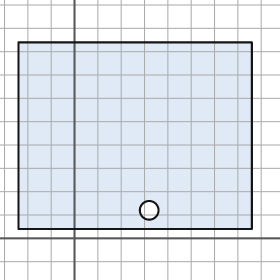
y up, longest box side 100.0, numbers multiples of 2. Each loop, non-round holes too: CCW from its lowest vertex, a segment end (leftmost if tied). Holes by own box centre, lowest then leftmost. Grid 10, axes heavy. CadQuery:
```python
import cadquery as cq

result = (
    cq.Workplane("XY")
    .moveTo(-24.0, 4.0)
    .lineTo(76.0, 4.0)
    .lineTo(76.0, 84.0)
    .lineTo(-24.0, 84.0)
    .close()
    .moveTo(32.0, 12.0)
    .circle(4.0)
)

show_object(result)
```